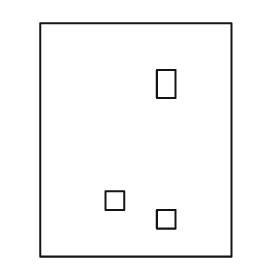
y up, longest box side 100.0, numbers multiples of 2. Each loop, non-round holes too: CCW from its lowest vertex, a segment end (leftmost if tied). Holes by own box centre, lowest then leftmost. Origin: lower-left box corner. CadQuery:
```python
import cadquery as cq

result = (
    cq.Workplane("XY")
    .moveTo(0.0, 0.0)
    .lineTo(82.0, 0.0)
    .lineTo(82.0, 100.0)
    .lineTo(0.0, 100.0)
    .close()
    .moveTo(50.0, 12.0)
    .lineTo(58.0, 12.0)
    .lineTo(58.0, 20.0)
    .lineTo(50.0, 20.0)
    .close()
    .moveTo(28.0, 20.0)
    .lineTo(36.0, 20.0)
    .lineTo(36.0, 28.0)
    .lineTo(28.0, 28.0)
    .close()
    .moveTo(50.0, 68.0)
    .lineTo(58.0, 68.0)
    .lineTo(58.0, 80.0)
    .lineTo(50.0, 80.0)
    .close()
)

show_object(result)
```